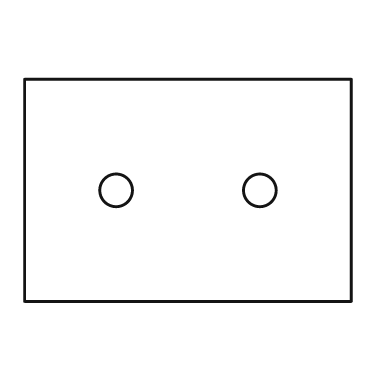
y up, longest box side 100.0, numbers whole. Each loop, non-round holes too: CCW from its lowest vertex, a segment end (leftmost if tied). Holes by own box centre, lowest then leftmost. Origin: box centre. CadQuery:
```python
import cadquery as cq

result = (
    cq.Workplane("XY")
    .moveTo(-50.0, -34.0)
    .lineTo(50.0, -34.0)
    .lineTo(50.0, 34.0)
    .lineTo(-50.0, 34.0)
    .close()
    .moveTo(-22.0, 0.0)
    .circle(5.0)
    .moveTo(22.0, 0.0)
    .circle(5.0)
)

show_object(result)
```